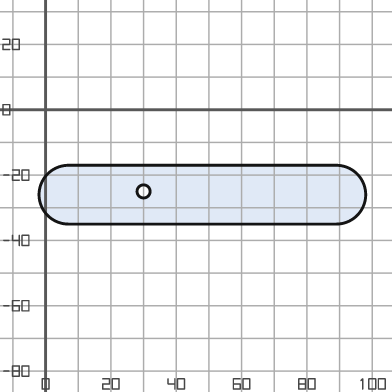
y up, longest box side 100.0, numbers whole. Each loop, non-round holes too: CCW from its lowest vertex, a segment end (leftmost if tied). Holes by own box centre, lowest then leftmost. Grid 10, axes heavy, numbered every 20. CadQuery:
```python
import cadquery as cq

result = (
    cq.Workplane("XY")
    .moveTo(7.0, -35.0)
    .lineTo(89.0, -35.0)
    .threePointArc((98.0, -26.0), (89.0, -17.0))
    .lineTo(7.0, -17.0)
    .threePointArc((-2.0, -26.0), (7.0, -35.0))
    .close()
    .moveTo(30.0, -25.0)
    .circle(2.0)
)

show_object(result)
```